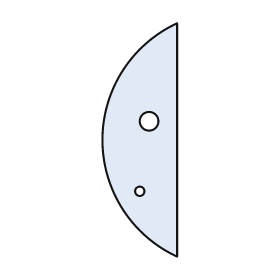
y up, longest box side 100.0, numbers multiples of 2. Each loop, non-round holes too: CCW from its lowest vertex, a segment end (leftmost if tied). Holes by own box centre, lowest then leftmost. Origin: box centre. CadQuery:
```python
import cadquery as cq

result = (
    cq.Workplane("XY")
    .moveTo(16.0, -50.0)
    .lineTo(16.0, 50.0)
    .threePointArc((-16.0, 0.0), (16.0, -50.0))
    .close()
    .moveTo(0.0, -22.0)
    .circle(2.0)
    .moveTo(4.0, 8.0)
    .circle(4.0)
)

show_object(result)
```